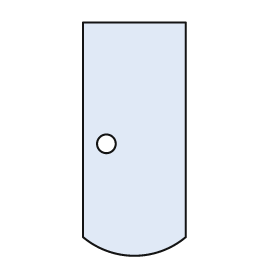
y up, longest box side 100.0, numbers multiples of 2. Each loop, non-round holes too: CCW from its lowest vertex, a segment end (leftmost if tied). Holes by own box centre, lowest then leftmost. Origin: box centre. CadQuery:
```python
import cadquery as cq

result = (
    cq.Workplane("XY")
    .moveTo(-22.0, -42.0)
    .threePointArc((0.0, -50.0), (22.0, -42.0))
    .lineTo(22.0, 50.0)
    .lineTo(-22.0, 50.0)
    .close()
    .moveTo(-12.0, -2.0)
    .circle(4.0)
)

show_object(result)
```